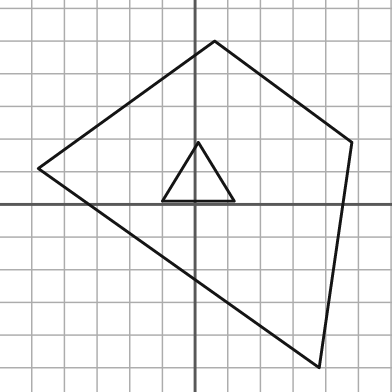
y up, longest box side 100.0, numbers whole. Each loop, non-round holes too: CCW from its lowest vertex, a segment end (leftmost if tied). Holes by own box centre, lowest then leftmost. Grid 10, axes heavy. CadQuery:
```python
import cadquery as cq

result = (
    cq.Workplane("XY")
    .moveTo(38.0, -50.0)
    .lineTo(48.0, 19.0)
    .lineTo(6.0, 50.0)
    .lineTo(-48.0, 11.0)
    .close()
    .moveTo(-10.0, 1.0)
    .lineTo(12.0, 1.0)
    .lineTo(1.0, 19.0)
    .close()
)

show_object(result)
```